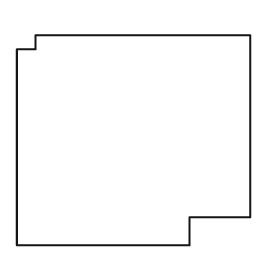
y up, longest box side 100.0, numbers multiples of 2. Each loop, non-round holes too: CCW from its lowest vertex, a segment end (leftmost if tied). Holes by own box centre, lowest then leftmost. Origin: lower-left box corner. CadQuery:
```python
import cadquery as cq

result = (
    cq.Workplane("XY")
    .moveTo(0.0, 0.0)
    .lineTo(74.0, 0.0)
    .lineTo(74.0, 12.0)
    .lineTo(100.0, 12.0)
    .lineTo(100.0, 90.0)
    .lineTo(8.0, 90.0)
    .lineTo(8.0, 84.0)
    .lineTo(0.0, 84.0)
    .close()
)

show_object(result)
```